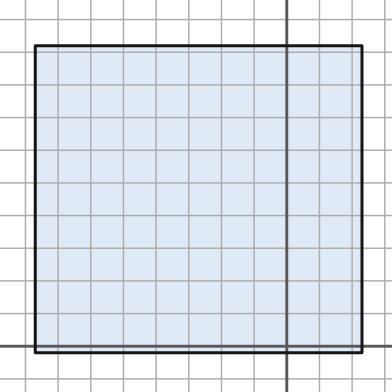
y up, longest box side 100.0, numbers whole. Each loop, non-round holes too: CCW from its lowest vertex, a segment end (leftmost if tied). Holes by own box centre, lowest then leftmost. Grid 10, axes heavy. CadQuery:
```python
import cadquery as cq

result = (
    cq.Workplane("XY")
    .moveTo(-77.0, -2.0)
    .lineTo(23.0, -2.0)
    .lineTo(23.0, 92.0)
    .lineTo(-77.0, 92.0)
    .close()
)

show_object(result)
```